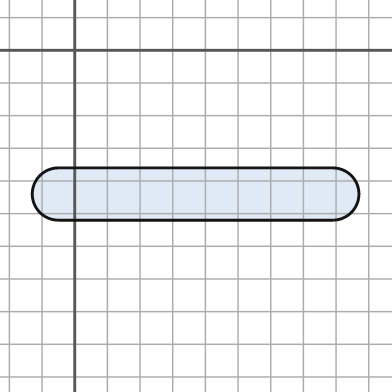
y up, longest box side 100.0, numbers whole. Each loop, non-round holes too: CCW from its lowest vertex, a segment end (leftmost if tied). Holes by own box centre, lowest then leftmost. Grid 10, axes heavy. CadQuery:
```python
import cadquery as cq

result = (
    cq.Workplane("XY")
    .moveTo(-5.0, -52.0)
    .lineTo(79.0, -52.0)
    .threePointArc((87.0, -44.0), (79.0, -36.0))
    .lineTo(-5.0, -36.0)
    .threePointArc((-13.0, -44.0), (-5.0, -52.0))
    .close()
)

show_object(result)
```